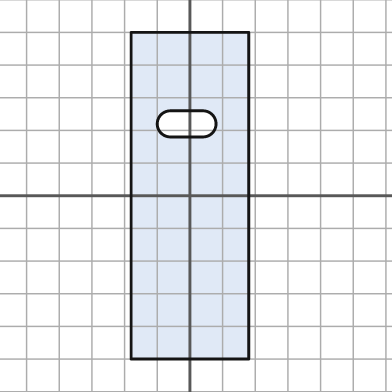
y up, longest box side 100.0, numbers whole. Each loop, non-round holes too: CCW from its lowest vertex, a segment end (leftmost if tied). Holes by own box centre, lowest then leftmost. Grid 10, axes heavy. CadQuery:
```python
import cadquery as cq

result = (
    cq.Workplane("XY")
    .moveTo(-18.0, -50.0)
    .lineTo(18.0, -50.0)
    .lineTo(18.0, 50.0)
    .lineTo(-18.0, 50.0)
    .close()
    .moveTo(-6.0, 18.0)
    .lineTo(4.0, 18.0)
    .threePointArc((8.0, 22.0), (4.0, 26.0))
    .lineTo(-6.0, 26.0)
    .threePointArc((-10.0, 22.0), (-6.0, 18.0))
    .close()
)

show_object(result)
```